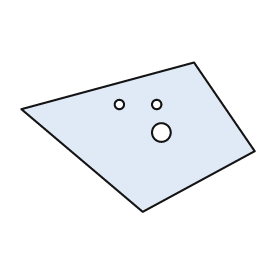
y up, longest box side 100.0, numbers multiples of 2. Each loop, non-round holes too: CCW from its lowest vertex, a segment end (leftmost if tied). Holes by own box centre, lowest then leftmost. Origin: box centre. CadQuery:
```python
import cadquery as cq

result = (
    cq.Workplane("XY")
    .moveTo(2.0, -32.0)
    .lineTo(50.0, -6.0)
    .lineTo(24.0, 32.0)
    .lineTo(-50.0, 12.0)
    .close()
    .moveTo(10.0, 2.0)
    .circle(4.0)
    .moveTo(-8.0, 14.0)
    .circle(2.0)
    .moveTo(8.0, 14.0)
    .circle(2.0)
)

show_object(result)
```